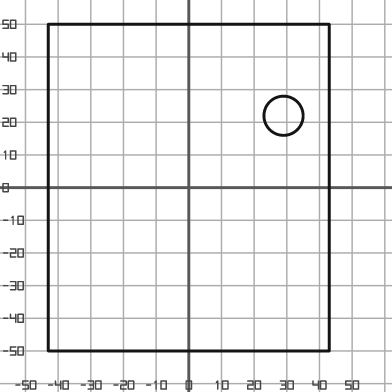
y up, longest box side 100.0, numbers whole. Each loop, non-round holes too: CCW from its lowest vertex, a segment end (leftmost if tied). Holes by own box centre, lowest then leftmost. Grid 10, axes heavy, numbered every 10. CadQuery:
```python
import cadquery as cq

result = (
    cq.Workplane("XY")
    .moveTo(-43.0, -50.0)
    .lineTo(43.0, -50.0)
    .lineTo(43.0, 50.0)
    .lineTo(-43.0, 50.0)
    .close()
    .moveTo(29.0, 22.0)
    .circle(6.0)
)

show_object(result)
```